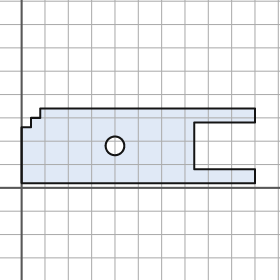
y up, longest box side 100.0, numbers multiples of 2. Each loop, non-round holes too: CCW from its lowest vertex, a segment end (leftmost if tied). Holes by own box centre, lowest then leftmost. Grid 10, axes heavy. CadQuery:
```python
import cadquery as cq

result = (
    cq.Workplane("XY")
    .moveTo(0.0, 2.0)
    .lineTo(100.0, 2.0)
    .lineTo(100.0, 8.0)
    .lineTo(74.0, 8.0)
    .lineTo(74.0, 28.0)
    .lineTo(100.0, 28.0)
    .lineTo(100.0, 34.0)
    .lineTo(8.0, 34.0)
    .lineTo(8.0, 30.0)
    .lineTo(4.0, 30.0)
    .lineTo(4.0, 26.0)
    .lineTo(0.0, 26.0)
    .close()
    .moveTo(40.0, 18.0)
    .circle(4.0)
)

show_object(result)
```